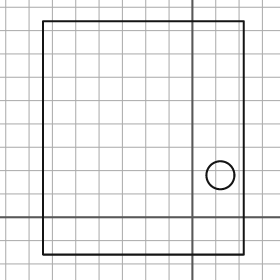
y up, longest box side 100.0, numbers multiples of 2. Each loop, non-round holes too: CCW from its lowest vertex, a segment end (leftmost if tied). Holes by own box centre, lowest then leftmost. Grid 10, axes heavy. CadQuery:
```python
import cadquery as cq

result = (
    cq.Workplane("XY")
    .moveTo(-64.0, -16.0)
    .lineTo(22.0, -16.0)
    .lineTo(22.0, 84.0)
    .lineTo(-64.0, 84.0)
    .close()
    .moveTo(12.0, 18.0)
    .circle(6.0)
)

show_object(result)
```